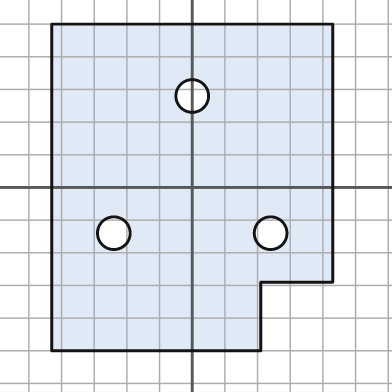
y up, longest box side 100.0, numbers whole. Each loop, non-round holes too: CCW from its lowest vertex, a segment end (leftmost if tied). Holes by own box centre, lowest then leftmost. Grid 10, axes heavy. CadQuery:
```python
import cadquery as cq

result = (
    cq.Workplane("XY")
    .moveTo(-43.0, -50.0)
    .lineTo(21.0, -50.0)
    .lineTo(21.0, -29.0)
    .lineTo(43.0, -29.0)
    .lineTo(43.0, 50.0)
    .lineTo(-43.0, 50.0)
    .close()
    .moveTo(-24.0, -14.0)
    .circle(5.0)
    .moveTo(24.0, -14.0)
    .circle(5.0)
    .moveTo(0.0, 28.0)
    .circle(5.0)
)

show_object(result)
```